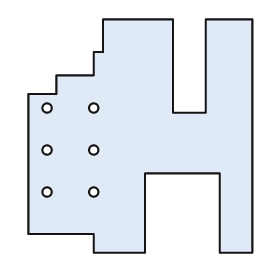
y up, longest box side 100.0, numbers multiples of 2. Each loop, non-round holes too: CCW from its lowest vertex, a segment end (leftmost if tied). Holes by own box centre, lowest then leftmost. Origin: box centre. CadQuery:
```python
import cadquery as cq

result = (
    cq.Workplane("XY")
    .moveTo(-20.0, -50.0)
    .lineTo(2.0, -50.0)
    .lineTo(2.0, -16.0)
    .lineTo(34.0, -16.0)
    .lineTo(34.0, -50.0)
    .lineTo(48.0, -50.0)
    .lineTo(48.0, 50.0)
    .lineTo(28.0, 50.0)
    .lineTo(28.0, 10.0)
    .lineTo(14.0, 10.0)
    .lineTo(14.0, 50.0)
    .lineTo(-16.0, 50.0)
    .lineTo(-16.0, 36.0)
    .lineTo(-20.0, 36.0)
    .lineTo(-20.0, 26.0)
    .lineTo(-36.0, 26.0)
    .lineTo(-36.0, 18.0)
    .lineTo(-48.0, 18.0)
    .lineTo(-48.0, -42.0)
    .lineTo(-20.0, -42.0)
    .close()
    .moveTo(-40.0, -24.0)
    .circle(2.0)
    .moveTo(-20.0, -24.0)
    .circle(2.0)
    .moveTo(-40.0, -6.0)
    .circle(2.0)
    .moveTo(-20.0, -6.0)
    .circle(2.0)
    .moveTo(-40.0, 12.0)
    .circle(2.0)
    .moveTo(-20.0, 12.0)
    .circle(2.0)
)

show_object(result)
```